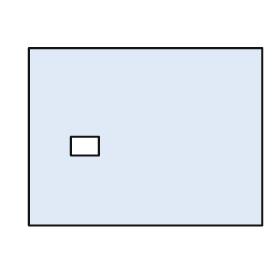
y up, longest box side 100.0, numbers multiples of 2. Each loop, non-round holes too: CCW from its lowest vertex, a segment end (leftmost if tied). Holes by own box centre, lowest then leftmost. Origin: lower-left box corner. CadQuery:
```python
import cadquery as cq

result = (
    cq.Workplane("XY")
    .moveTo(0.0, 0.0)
    .lineTo(100.0, 0.0)
    .lineTo(100.0, 76.0)
    .lineTo(0.0, 76.0)
    .close()
    .moveTo(18.0, 30.0)
    .lineTo(30.0, 30.0)
    .lineTo(30.0, 38.0)
    .lineTo(18.0, 38.0)
    .close()
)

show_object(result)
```